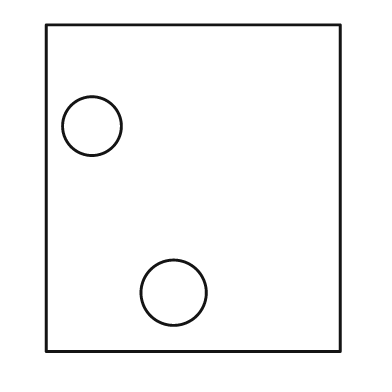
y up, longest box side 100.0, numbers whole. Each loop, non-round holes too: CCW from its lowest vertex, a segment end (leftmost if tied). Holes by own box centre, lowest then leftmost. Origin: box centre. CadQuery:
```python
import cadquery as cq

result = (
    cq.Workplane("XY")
    .moveTo(-45.0, -50.0)
    .lineTo(45.0, -50.0)
    .lineTo(45.0, 50.0)
    .lineTo(-45.0, 50.0)
    .close()
    .moveTo(-6.0, -32.0)
    .circle(10.0)
    .moveTo(-31.0, 19.0)
    .circle(9.0)
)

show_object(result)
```